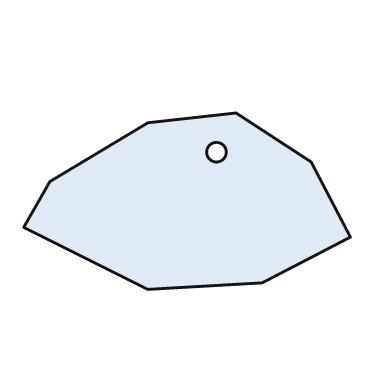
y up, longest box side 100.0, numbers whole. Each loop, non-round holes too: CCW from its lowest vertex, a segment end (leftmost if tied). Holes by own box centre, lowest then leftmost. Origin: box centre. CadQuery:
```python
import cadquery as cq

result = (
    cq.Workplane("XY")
    .moveTo(-12.0, -27.0)
    .lineTo(23.0, -25.0)
    .lineTo(50.0, -11.0)
    .lineTo(38.0, 12.0)
    .lineTo(15.0, 27.0)
    .lineTo(-12.0, 24.0)
    .lineTo(-42.0, 6.0)
    .lineTo(-50.0, -8.0)
    .close()
    .moveTo(9.0, 15.0)
    .circle(3.0)
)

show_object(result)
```